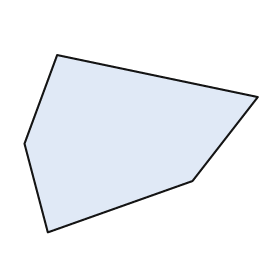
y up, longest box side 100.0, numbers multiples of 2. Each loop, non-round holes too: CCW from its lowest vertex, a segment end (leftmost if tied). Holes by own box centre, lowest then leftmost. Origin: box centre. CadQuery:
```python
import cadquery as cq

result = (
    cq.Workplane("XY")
    .moveTo(-40.0, -38.0)
    .lineTo(22.0, -16.0)
    .lineTo(50.0, 20.0)
    .lineTo(-36.0, 38.0)
    .lineTo(-50.0, 0.0)
    .close()
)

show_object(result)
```